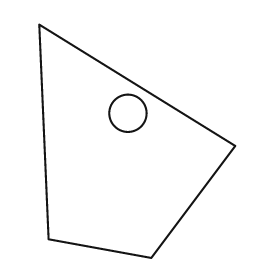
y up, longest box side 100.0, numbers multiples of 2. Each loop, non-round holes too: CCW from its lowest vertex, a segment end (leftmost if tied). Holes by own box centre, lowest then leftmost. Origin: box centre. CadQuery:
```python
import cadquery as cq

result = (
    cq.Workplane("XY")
    .moveTo(6.0, -50.0)
    .lineTo(42.0, -2.0)
    .lineTo(-42.0, 50.0)
    .lineTo(-38.0, -42.0)
    .close()
    .moveTo(-4.0, 12.0)
    .circle(8.0)
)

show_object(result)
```